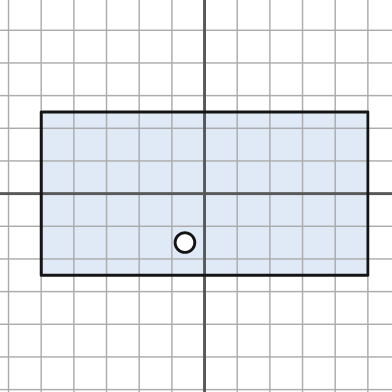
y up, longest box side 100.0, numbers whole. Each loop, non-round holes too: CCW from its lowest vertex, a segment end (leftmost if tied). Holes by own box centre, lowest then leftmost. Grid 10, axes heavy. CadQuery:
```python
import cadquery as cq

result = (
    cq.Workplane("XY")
    .moveTo(-50.0, -25.0)
    .lineTo(50.0, -25.0)
    .lineTo(50.0, 25.0)
    .lineTo(-50.0, 25.0)
    .close()
    .moveTo(-6.0, -15.0)
    .circle(3.0)
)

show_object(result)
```